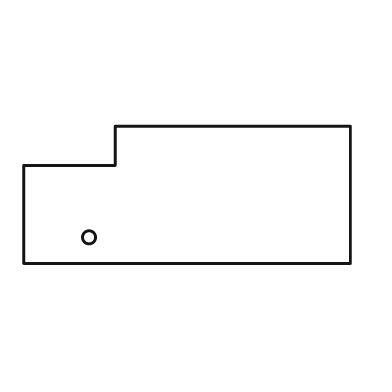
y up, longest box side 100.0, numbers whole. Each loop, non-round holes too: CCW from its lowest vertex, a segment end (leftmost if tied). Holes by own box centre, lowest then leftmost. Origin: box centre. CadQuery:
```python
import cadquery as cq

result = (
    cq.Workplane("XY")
    .moveTo(-50.0, -21.0)
    .lineTo(50.0, -21.0)
    .lineTo(50.0, 21.0)
    .lineTo(-22.0, 21.0)
    .lineTo(-22.0, 9.0)
    .lineTo(-50.0, 9.0)
    .close()
    .moveTo(-30.0, -13.0)
    .circle(2.0)
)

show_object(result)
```